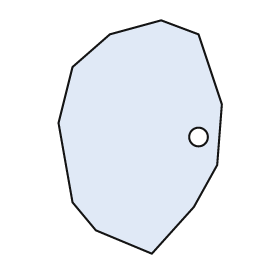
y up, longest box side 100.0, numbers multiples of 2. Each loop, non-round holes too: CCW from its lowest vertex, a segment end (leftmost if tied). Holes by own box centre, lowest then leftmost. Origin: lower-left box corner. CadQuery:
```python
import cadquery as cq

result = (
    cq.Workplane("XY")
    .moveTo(40.0, 0.0)
    .lineTo(58.0, 20.0)
    .lineTo(68.0, 38.0)
    .lineTo(70.0, 64.0)
    .lineTo(60.0, 94.0)
    .lineTo(44.0, 100.0)
    .lineTo(22.0, 94.0)
    .lineTo(6.0, 80.0)
    .lineTo(0.0, 56.0)
    .lineTo(6.0, 22.0)
    .lineTo(16.0, 10.0)
    .close()
    .moveTo(60.0, 50.0)
    .circle(4.0)
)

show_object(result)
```